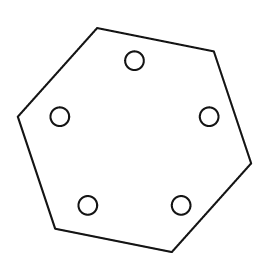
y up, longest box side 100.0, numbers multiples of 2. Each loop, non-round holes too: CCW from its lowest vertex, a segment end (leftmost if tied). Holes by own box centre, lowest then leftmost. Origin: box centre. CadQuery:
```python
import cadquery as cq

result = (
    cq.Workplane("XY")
    .moveTo(16.0, -48.0)
    .lineTo(50.0, -10.0)
    .lineTo(34.0, 38.0)
    .lineTo(-16.0, 48.0)
    .lineTo(-50.0, 10.0)
    .lineTo(-34.0, -38.0)
    .close()
    .moveTo(-20.0, -28.0)
    .circle(4.0)
    .moveTo(20.0, -28.0)
    .circle(4.0)
    .moveTo(-32.0, 10.0)
    .circle(4.0)
    .moveTo(32.0, 10.0)
    .circle(4.0)
    .moveTo(0.0, 34.0)
    .circle(4.0)
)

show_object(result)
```